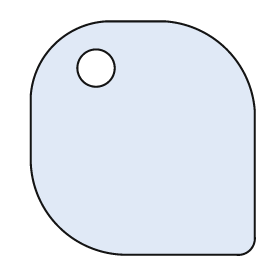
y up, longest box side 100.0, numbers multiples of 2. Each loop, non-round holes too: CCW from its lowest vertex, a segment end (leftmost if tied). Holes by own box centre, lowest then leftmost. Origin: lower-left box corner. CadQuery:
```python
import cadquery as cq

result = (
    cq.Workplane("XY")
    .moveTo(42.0, 0.0)
    .lineTo(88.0, 0.0)
    .threePointArc((94.0, 2.0), (96.0, 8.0))
    .lineTo(96.0, 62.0)
    .threePointArc((84.0, 88.0), (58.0, 100.0))
    .lineTo(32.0, 100.0)
    .threePointArc((10.0, 90.0), (0.0, 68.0))
    .lineTo(0.0, 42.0)
    .threePointArc((12.0, 12.0), (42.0, 0.0))
    .close()
    .moveTo(28.0, 80.0)
    .circle(8.0)
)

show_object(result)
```